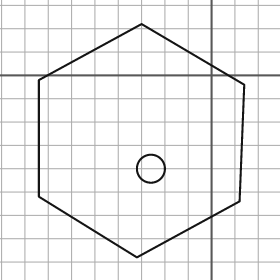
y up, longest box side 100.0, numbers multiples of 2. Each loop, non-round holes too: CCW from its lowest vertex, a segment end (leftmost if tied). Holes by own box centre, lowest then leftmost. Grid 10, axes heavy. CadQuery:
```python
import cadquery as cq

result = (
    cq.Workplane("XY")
    .moveTo(-32.0, -78.0)
    .lineTo(12.0, -54.0)
    .lineTo(14.0, -4.0)
    .lineTo(-30.0, 22.0)
    .lineTo(-74.0, -2.0)
    .lineTo(-74.0, -52.0)
    .close()
    .moveTo(-26.0, -40.0)
    .circle(6.0)
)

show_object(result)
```